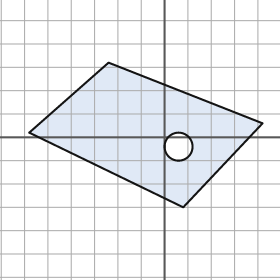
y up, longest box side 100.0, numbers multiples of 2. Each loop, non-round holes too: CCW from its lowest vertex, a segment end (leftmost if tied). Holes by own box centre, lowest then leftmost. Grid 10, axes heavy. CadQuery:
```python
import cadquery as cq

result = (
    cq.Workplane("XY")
    .moveTo(8.0, -30.0)
    .lineTo(42.0, 6.0)
    .lineTo(-24.0, 32.0)
    .lineTo(-58.0, 2.0)
    .close()
    .moveTo(6.0, -4.0)
    .circle(6.0)
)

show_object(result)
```